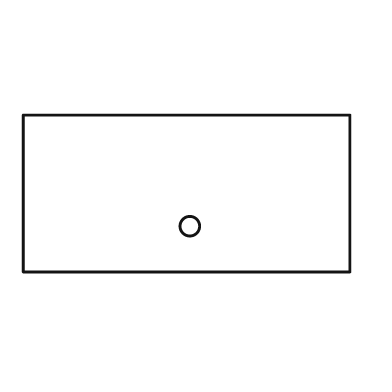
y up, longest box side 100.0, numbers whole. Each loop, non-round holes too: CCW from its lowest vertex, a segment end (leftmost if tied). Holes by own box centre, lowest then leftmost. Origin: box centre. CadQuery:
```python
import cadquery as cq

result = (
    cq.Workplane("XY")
    .moveTo(-50.0, -24.0)
    .lineTo(50.0, -24.0)
    .lineTo(50.0, 24.0)
    .lineTo(-50.0, 24.0)
    .close()
    .moveTo(1.0, -10.0)
    .circle(3.0)
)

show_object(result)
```